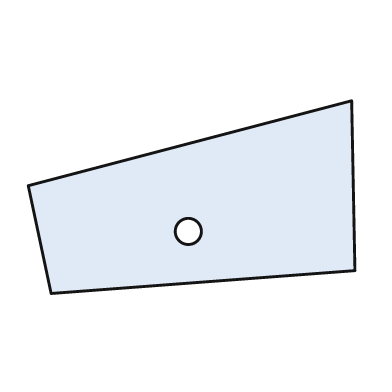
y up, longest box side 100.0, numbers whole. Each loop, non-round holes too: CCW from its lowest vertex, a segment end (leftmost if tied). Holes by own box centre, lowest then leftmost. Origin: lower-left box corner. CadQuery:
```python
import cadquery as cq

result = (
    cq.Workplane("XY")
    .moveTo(7.0, 0.0)
    .lineTo(100.0, 7.0)
    .lineTo(99.0, 59.0)
    .lineTo(0.0, 33.0)
    .close()
    .moveTo(49.0, 19.0)
    .circle(4.0)
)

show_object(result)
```